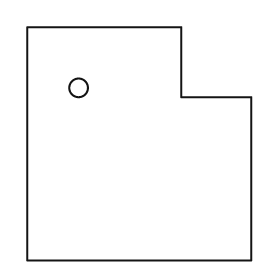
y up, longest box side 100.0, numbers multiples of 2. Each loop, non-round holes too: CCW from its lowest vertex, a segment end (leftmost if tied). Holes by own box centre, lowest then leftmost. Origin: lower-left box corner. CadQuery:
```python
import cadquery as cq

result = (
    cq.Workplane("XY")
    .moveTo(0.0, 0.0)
    .lineTo(96.0, 0.0)
    .lineTo(96.0, 70.0)
    .lineTo(66.0, 70.0)
    .lineTo(66.0, 100.0)
    .lineTo(0.0, 100.0)
    .close()
    .moveTo(22.0, 74.0)
    .circle(4.0)
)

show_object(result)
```